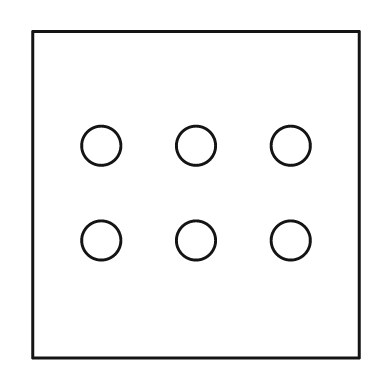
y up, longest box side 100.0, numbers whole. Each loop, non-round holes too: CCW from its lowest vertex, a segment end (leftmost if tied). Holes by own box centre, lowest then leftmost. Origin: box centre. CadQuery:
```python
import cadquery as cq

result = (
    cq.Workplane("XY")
    .moveTo(-50.0, -50.0)
    .lineTo(50.0, -50.0)
    .lineTo(50.0, 50.0)
    .lineTo(-50.0, 50.0)
    .close()
    .moveTo(-29.0, -14.0)
    .circle(6.0)
    .moveTo(0.0, -14.0)
    .circle(6.0)
    .moveTo(29.0, -14.0)
    .circle(6.0)
    .moveTo(-29.0, 15.0)
    .circle(6.0)
    .moveTo(0.0, 15.0)
    .circle(6.0)
    .moveTo(29.0, 15.0)
    .circle(6.0)
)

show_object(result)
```